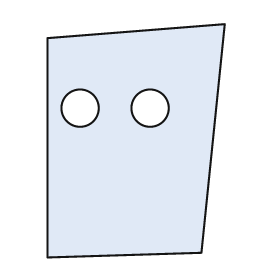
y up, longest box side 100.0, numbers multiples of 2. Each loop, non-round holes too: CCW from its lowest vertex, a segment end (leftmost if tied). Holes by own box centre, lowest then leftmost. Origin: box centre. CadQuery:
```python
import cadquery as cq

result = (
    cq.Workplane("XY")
    .moveTo(-38.0, -50.0)
    .lineTo(28.0, -48.0)
    .lineTo(38.0, 50.0)
    .lineTo(-38.0, 44.0)
    .close()
    .moveTo(-24.0, 14.0)
    .circle(8.0)
    .moveTo(6.0, 14.0)
    .circle(8.0)
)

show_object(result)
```